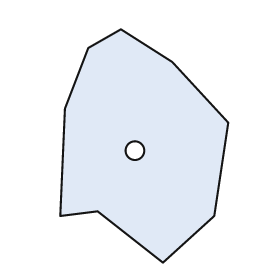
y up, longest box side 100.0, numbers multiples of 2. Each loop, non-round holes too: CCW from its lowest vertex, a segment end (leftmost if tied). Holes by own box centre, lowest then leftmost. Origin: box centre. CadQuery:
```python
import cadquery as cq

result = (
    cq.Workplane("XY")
    .moveTo(8.0, -50.0)
    .lineTo(30.0, -30.0)
    .lineTo(36.0, 10.0)
    .lineTo(12.0, 36.0)
    .lineTo(-10.0, 50.0)
    .lineTo(-24.0, 42.0)
    .lineTo(-34.0, 16.0)
    .lineTo(-36.0, -30.0)
    .lineTo(-20.0, -28.0)
    .close()
    .moveTo(-4.0, -2.0)
    .circle(4.0)
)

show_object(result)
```